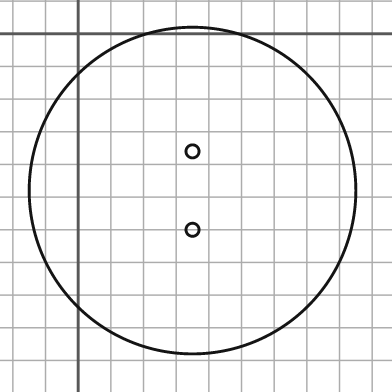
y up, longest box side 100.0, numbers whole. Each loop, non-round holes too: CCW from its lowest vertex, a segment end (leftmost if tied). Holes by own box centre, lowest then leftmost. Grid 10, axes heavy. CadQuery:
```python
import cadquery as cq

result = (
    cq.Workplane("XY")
    .moveTo(35.0, -48.0)
    .circle(50.0)
    .moveTo(35.0, -60.0)
    .circle(2.0)
    .moveTo(35.0, -36.0)
    .circle(2.0)
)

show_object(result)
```